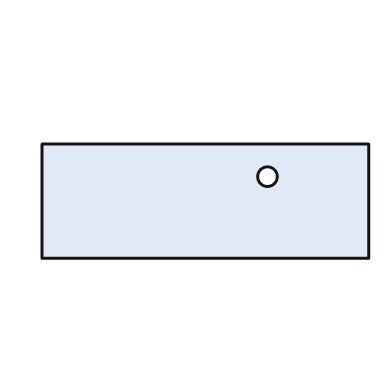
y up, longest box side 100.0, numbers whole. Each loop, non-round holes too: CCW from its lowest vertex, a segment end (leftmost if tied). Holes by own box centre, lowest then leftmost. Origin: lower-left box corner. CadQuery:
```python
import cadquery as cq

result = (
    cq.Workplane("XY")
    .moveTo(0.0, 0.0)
    .lineTo(100.0, 0.0)
    .lineTo(100.0, 35.0)
    .lineTo(0.0, 35.0)
    .close()
    .moveTo(69.0, 25.0)
    .circle(3.0)
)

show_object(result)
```